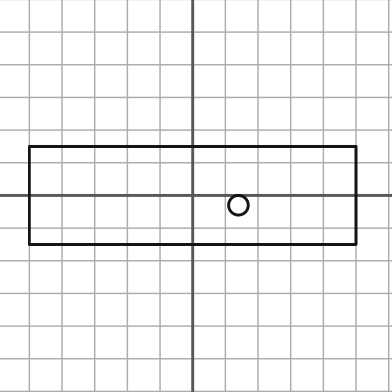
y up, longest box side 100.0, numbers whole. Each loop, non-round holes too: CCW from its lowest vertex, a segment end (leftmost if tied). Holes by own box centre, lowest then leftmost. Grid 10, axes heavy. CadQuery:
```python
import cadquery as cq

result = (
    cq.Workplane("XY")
    .moveTo(-50.0, -15.0)
    .lineTo(50.0, -15.0)
    .lineTo(50.0, 15.0)
    .lineTo(-50.0, 15.0)
    .close()
    .moveTo(14.0, -3.0)
    .circle(3.0)
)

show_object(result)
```